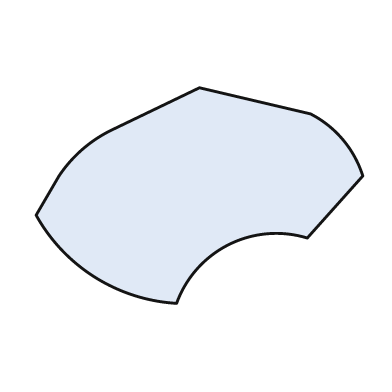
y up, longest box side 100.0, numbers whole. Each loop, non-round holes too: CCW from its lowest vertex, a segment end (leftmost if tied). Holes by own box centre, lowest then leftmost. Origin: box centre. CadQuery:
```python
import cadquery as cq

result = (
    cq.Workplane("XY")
    .moveTo(-7.0, -33.0)
    .threePointArc((9.0, -15.0), (33.0, -13.0))
    .lineTo(50.0, 6.0)
    .threePointArc((44.0, 17.0), (34.0, 25.0))
    .lineTo(0.0, 33.0)
    .lineTo(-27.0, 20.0)
    .threePointArc((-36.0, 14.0), (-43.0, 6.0))
    .lineTo(-50.0, -6.0)
    .threePointArc((-32.0, -25.0), (-7.0, -33.0))
    .close()
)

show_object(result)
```